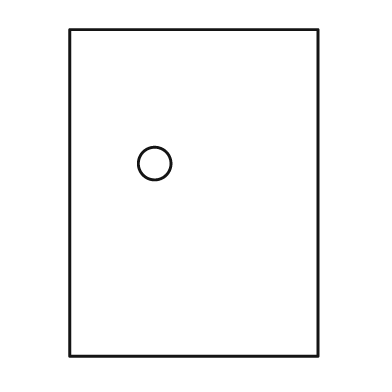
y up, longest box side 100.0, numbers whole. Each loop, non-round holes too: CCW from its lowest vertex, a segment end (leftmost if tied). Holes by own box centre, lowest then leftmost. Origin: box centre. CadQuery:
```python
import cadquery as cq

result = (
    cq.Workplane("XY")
    .moveTo(-38.0, -50.0)
    .lineTo(38.0, -50.0)
    .lineTo(38.0, 50.0)
    .lineTo(-38.0, 50.0)
    .close()
    .moveTo(-12.0, 9.0)
    .circle(5.0)
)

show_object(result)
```